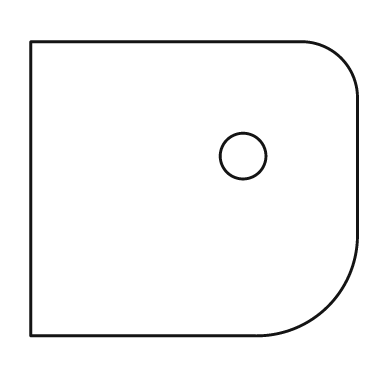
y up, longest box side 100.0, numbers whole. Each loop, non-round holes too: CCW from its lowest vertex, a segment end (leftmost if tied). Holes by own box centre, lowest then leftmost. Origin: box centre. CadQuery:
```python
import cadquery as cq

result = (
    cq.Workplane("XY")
    .moveTo(-50.0, -45.0)
    .lineTo(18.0, -45.0)
    .threePointArc((41.0, -36.0), (50.0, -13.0))
    .lineTo(50.0, 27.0)
    .threePointArc((45.0, 40.0), (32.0, 45.0))
    .lineTo(-50.0, 45.0)
    .close()
    .moveTo(15.0, 10.0)
    .circle(7.0)
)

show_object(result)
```